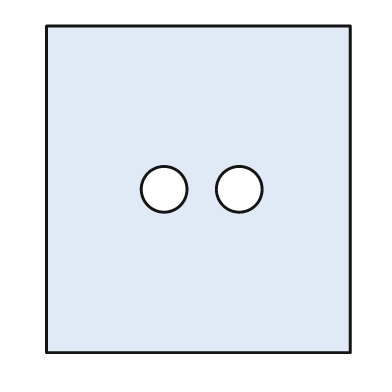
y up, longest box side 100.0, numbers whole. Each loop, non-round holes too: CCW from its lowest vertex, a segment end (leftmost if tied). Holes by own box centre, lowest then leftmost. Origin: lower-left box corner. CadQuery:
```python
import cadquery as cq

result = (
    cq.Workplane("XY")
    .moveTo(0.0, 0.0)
    .lineTo(93.0, 0.0)
    .lineTo(93.0, 100.0)
    .lineTo(0.0, 100.0)
    .close()
    .moveTo(36.0, 50.0)
    .circle(7.0)
    .moveTo(59.0, 50.0)
    .circle(7.0)
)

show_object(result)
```